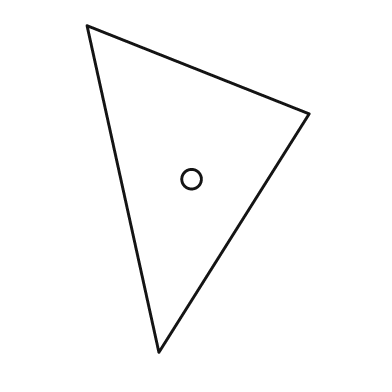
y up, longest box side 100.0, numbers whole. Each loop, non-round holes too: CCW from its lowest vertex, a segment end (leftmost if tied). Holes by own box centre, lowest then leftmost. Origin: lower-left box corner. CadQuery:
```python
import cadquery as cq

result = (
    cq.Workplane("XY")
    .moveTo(22.0, 0.0)
    .lineTo(68.0, 73.0)
    .lineTo(0.0, 100.0)
    .close()
    .moveTo(32.0, 53.0)
    .circle(3.0)
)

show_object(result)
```